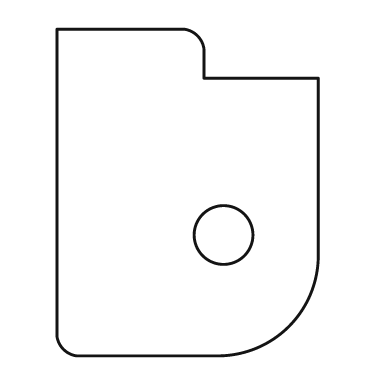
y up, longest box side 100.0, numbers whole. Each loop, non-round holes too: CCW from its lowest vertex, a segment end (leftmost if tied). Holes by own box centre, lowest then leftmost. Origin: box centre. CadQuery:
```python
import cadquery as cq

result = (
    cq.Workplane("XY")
    .moveTo(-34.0, -50.0)
    .lineTo(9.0, -50.0)
    .threePointArc((31.0, -41.0), (40.0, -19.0))
    .lineTo(40.0, 35.0)
    .lineTo(5.0, 35.0)
    .lineTo(5.0, 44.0)
    .threePointArc((3.0, 48.0), (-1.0, 50.0))
    .lineTo(-40.0, 50.0)
    .lineTo(-40.0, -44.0)
    .threePointArc((-38.0, -48.0), (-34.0, -50.0))
    .close()
    .moveTo(11.0, -13.0)
    .circle(9.0)
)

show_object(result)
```